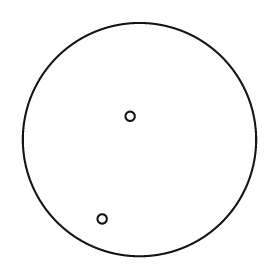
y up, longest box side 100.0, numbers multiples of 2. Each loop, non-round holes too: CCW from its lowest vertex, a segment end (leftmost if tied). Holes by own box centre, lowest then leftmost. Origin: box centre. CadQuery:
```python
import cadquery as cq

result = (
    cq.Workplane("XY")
    .moveTo(0.0, 0.0)
    .circle(50.0)
    .moveTo(-16.0, -34.0)
    .circle(2.0)
    .moveTo(-4.0, 10.0)
    .circle(2.0)
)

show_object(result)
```